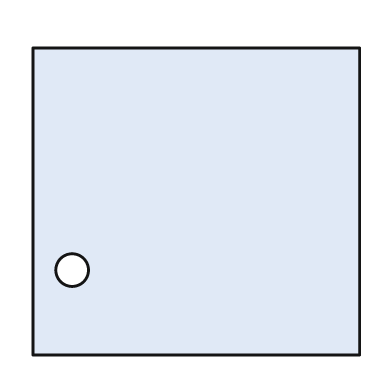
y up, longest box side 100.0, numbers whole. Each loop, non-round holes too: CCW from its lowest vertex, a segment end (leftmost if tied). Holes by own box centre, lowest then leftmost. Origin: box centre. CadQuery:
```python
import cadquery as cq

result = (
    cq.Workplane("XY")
    .moveTo(-50.0, -47.0)
    .lineTo(50.0, -47.0)
    .lineTo(50.0, 47.0)
    .lineTo(-50.0, 47.0)
    .close()
    .moveTo(-38.0, -21.0)
    .circle(5.0)
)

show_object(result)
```